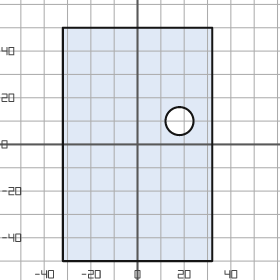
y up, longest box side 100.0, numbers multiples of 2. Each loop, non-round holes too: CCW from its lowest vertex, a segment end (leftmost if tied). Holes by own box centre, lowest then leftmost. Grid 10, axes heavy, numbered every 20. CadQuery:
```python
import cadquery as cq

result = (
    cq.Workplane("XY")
    .moveTo(-32.0, -50.0)
    .lineTo(32.0, -50.0)
    .lineTo(32.0, 50.0)
    .lineTo(-32.0, 50.0)
    .close()
    .moveTo(18.0, 10.0)
    .circle(6.0)
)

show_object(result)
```